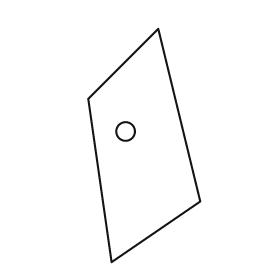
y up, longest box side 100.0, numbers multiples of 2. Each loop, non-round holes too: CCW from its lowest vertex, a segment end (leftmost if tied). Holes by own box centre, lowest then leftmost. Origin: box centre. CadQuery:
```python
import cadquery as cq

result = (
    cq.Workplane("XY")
    .moveTo(-14.0, -50.0)
    .lineTo(24.0, -24.0)
    .lineTo(6.0, 50.0)
    .lineTo(-24.0, 20.0)
    .close()
    .moveTo(-8.0, 6.0)
    .circle(4.0)
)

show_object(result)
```